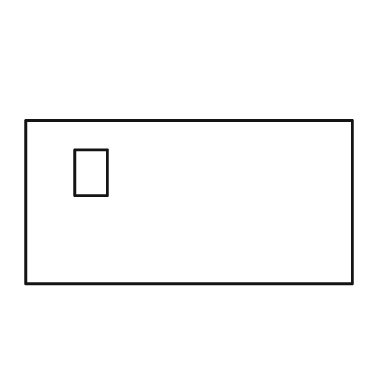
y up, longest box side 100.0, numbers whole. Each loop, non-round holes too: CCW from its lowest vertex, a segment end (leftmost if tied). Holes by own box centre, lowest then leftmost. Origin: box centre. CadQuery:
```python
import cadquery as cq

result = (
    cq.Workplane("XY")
    .moveTo(-50.0, -25.0)
    .lineTo(50.0, -25.0)
    .lineTo(50.0, 25.0)
    .lineTo(-50.0, 25.0)
    .close()
    .moveTo(-35.0, 2.0)
    .lineTo(-25.0, 2.0)
    .lineTo(-25.0, 16.0)
    .lineTo(-35.0, 16.0)
    .close()
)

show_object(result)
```